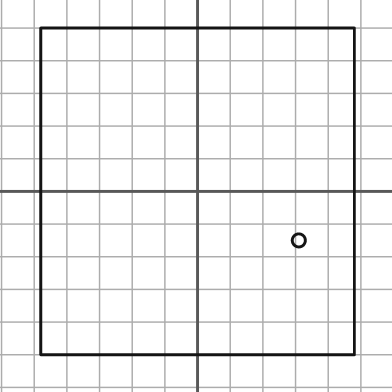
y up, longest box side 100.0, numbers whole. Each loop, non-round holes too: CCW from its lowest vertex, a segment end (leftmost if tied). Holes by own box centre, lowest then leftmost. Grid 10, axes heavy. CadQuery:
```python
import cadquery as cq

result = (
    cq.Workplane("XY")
    .moveTo(-48.0, -50.0)
    .lineTo(48.0, -50.0)
    .lineTo(48.0, 50.0)
    .lineTo(-48.0, 50.0)
    .close()
    .moveTo(31.0, -15.0)
    .circle(2.0)
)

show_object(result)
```